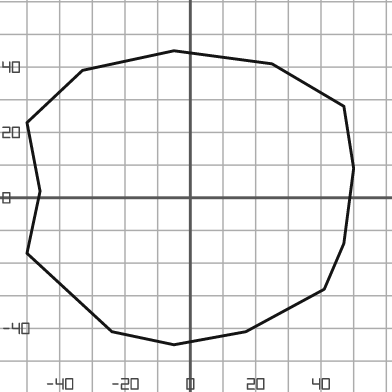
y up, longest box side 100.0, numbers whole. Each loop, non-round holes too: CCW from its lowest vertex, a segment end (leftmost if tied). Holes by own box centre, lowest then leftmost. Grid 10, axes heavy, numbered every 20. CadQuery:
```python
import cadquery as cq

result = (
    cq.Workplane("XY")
    .moveTo(-5.0, -45.0)
    .lineTo(17.0, -41.0)
    .lineTo(41.0, -28.0)
    .lineTo(47.0, -14.0)
    .lineTo(50.0, 9.0)
    .lineTo(47.0, 28.0)
    .lineTo(25.0, 41.0)
    .lineTo(-5.0, 45.0)
    .lineTo(-33.0, 39.0)
    .lineTo(-50.0, 23.0)
    .lineTo(-46.0, 2.0)
    .lineTo(-50.0, -17.0)
    .lineTo(-24.0, -41.0)
    .close()
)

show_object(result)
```